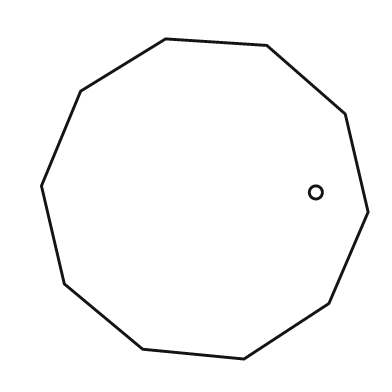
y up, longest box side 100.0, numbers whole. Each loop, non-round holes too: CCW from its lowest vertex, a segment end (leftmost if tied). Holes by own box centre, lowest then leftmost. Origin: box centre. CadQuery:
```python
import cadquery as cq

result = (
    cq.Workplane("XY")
    .moveTo(12.0, -49.0)
    .lineTo(38.0, -32.0)
    .lineTo(50.0, -4.0)
    .lineTo(43.0, 26.0)
    .lineTo(19.0, 47.0)
    .lineTo(-12.0, 49.0)
    .lineTo(-38.0, 33.0)
    .lineTo(-50.0, 4.0)
    .lineTo(-43.0, -26.0)
    .lineTo(-19.0, -46.0)
    .close()
    .moveTo(34.0, 2.0)
    .circle(2.0)
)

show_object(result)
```